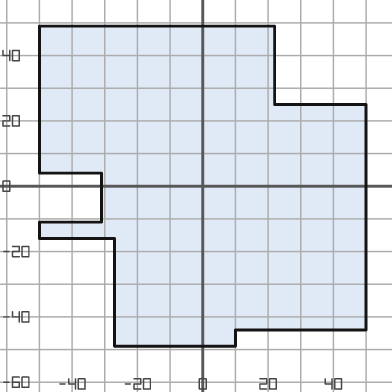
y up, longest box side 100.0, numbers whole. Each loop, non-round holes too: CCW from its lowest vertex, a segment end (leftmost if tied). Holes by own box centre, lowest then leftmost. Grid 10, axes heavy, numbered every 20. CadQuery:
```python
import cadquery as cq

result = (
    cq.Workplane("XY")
    .moveTo(-27.0, -49.0)
    .lineTo(10.0, -49.0)
    .lineTo(10.0, -44.0)
    .lineTo(50.0, -44.0)
    .lineTo(50.0, 25.0)
    .lineTo(22.0, 25.0)
    .lineTo(22.0, 49.0)
    .lineTo(-50.0, 49.0)
    .lineTo(-50.0, 4.0)
    .lineTo(-31.0, 4.0)
    .lineTo(-31.0, -11.0)
    .lineTo(-50.0, -11.0)
    .lineTo(-50.0, -16.0)
    .lineTo(-27.0, -16.0)
    .close()
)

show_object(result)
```